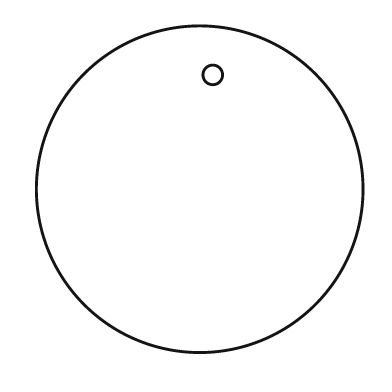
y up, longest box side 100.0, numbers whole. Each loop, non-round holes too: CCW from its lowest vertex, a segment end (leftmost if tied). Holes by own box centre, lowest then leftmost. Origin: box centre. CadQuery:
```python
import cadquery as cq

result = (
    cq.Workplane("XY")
    .moveTo(0.0, 0.0)
    .circle(50.0)
    .moveTo(4.0, 35.0)
    .circle(3.0)
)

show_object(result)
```